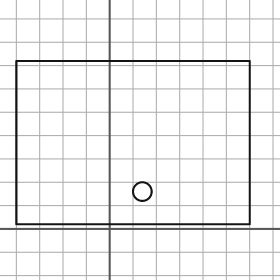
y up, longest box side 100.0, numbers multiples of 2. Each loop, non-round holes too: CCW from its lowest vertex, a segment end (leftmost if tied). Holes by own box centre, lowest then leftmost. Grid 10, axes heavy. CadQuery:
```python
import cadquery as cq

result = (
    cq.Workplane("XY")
    .moveTo(-40.0, 2.0)
    .lineTo(60.0, 2.0)
    .lineTo(60.0, 72.0)
    .lineTo(-40.0, 72.0)
    .close()
    .moveTo(14.0, 16.0)
    .circle(4.0)
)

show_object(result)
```